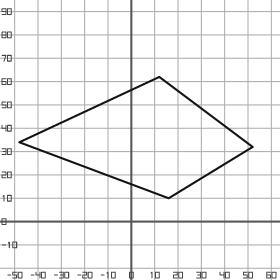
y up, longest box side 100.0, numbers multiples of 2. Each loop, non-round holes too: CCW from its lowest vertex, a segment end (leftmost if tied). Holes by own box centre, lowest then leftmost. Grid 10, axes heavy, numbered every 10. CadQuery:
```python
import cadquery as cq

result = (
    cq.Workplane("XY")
    .moveTo(16.0, 10.0)
    .lineTo(52.0, 32.0)
    .lineTo(12.0, 62.0)
    .lineTo(-48.0, 34.0)
    .close()
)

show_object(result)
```